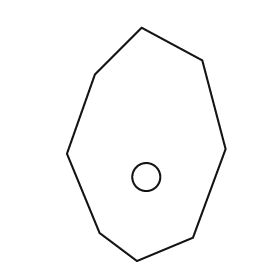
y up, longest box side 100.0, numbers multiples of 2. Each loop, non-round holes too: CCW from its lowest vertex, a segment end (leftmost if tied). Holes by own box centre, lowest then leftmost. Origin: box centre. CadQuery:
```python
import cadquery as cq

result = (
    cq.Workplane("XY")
    .moveTo(-4.0, -50.0)
    .lineTo(20.0, -40.0)
    .lineTo(34.0, -2.0)
    .lineTo(24.0, 36.0)
    .lineTo(-2.0, 50.0)
    .lineTo(-22.0, 30.0)
    .lineTo(-34.0, -4.0)
    .lineTo(-20.0, -38.0)
    .close()
    .moveTo(0.0, -14.0)
    .circle(6.0)
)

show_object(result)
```